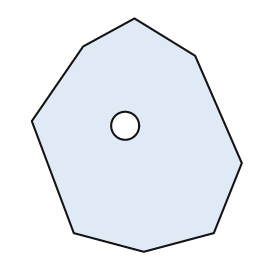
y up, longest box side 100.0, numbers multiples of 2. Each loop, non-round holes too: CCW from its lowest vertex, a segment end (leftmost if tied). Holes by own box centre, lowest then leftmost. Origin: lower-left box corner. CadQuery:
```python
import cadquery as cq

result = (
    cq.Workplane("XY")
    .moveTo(48.0, 0.0)
    .lineTo(78.0, 8.0)
    .lineTo(90.0, 38.0)
    .lineTo(70.0, 84.0)
    .lineTo(44.0, 100.0)
    .lineTo(22.0, 88.0)
    .lineTo(0.0, 56.0)
    .lineTo(18.0, 8.0)
    .close()
    .moveTo(40.0, 54.0)
    .circle(6.0)
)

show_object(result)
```